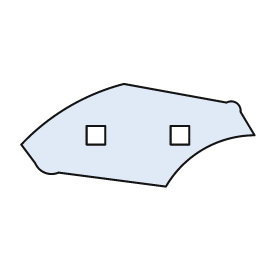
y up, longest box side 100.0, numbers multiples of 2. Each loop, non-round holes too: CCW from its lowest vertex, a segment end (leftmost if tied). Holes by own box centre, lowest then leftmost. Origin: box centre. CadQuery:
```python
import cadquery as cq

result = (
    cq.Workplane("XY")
    .moveTo(12.0, -22.0)
    .threePointArc((28.0, -6.0), (50.0, 0.0))
    .lineTo(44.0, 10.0)
    .threePointArc((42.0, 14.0), (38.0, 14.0))
    .lineTo(-6.0, 22.0)
    .threePointArc((-30.0, 12.0), (-50.0, -4.0))
    .lineTo(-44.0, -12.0)
    .threePointArc((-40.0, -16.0), (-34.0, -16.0))
    .close()
    .moveTo(-22.0, -4.0)
    .lineTo(-14.0, -4.0)
    .lineTo(-14.0, 4.0)
    .lineTo(-22.0, 4.0)
    .close()
    .moveTo(14.0, -4.0)
    .lineTo(22.0, -4.0)
    .lineTo(22.0, 4.0)
    .lineTo(14.0, 4.0)
    .close()
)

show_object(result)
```